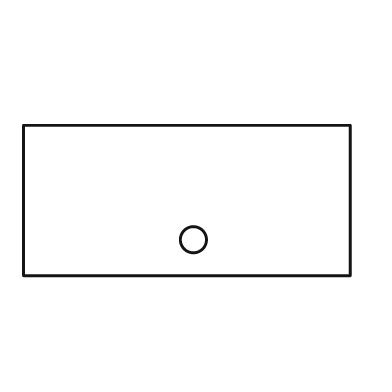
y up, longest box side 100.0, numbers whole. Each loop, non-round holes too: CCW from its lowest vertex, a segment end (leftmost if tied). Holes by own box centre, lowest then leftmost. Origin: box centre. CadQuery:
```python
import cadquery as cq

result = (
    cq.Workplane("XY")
    .moveTo(-50.0, -23.0)
    .lineTo(50.0, -23.0)
    .lineTo(50.0, 23.0)
    .lineTo(-50.0, 23.0)
    .close()
    .moveTo(2.0, -12.0)
    .circle(4.0)
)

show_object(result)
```